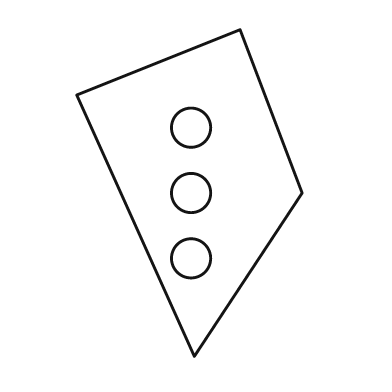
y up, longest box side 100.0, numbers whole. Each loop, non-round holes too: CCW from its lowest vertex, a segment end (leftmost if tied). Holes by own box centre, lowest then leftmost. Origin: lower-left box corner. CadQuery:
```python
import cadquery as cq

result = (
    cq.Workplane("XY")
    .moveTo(36.0, 0.0)
    .lineTo(69.0, 50.0)
    .lineTo(50.0, 100.0)
    .lineTo(0.0, 80.0)
    .close()
    .moveTo(35.0, 30.0)
    .circle(6.0)
    .moveTo(35.0, 50.0)
    .circle(6.0)
    .moveTo(35.0, 70.0)
    .circle(6.0)
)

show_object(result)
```